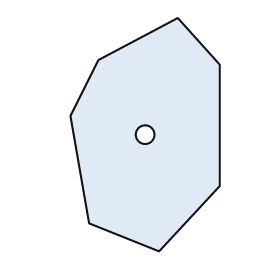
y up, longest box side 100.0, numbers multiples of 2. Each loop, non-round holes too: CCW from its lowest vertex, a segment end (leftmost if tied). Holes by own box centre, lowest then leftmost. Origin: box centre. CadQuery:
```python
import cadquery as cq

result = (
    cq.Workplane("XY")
    .moveTo(6.0, -50.0)
    .lineTo(32.0, -22.0)
    .lineTo(32.0, 30.0)
    .lineTo(14.0, 50.0)
    .lineTo(-20.0, 32.0)
    .lineTo(-32.0, 8.0)
    .lineTo(-24.0, -38.0)
    .close()
    .moveTo(0.0, 0.0)
    .circle(4.0)
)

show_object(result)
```